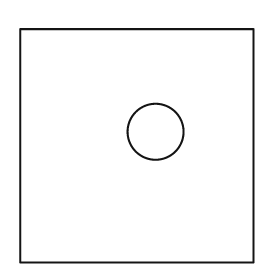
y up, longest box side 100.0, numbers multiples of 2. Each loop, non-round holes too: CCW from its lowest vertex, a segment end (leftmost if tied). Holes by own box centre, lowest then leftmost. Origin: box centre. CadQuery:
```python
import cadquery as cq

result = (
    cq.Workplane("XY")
    .moveTo(-50.0, -50.0)
    .lineTo(50.0, -50.0)
    .lineTo(50.0, 50.0)
    .lineTo(-50.0, 50.0)
    .close()
    .moveTo(8.0, 6.0)
    .circle(12.0)
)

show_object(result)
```